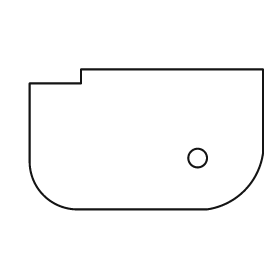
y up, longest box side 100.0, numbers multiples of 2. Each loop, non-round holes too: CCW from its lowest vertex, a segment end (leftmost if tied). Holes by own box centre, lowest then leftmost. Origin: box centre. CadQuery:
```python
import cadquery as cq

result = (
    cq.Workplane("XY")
    .moveTo(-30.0, -30.0)
    .lineTo(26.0, -30.0)
    .threePointArc((42.0, -22.0), (50.0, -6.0))
    .lineTo(50.0, 30.0)
    .lineTo(-28.0, 30.0)
    .lineTo(-28.0, 24.0)
    .lineTo(-50.0, 24.0)
    .lineTo(-50.0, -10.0)
    .threePointArc((-44.0, -24.0), (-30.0, -30.0))
    .close()
    .moveTo(22.0, -8.0)
    .circle(4.0)
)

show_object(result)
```